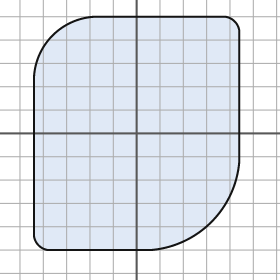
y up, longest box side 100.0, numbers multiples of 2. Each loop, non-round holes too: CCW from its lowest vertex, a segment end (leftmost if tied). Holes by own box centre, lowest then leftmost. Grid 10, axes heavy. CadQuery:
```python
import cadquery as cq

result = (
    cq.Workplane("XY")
    .moveTo(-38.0, -50.0)
    .lineTo(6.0, -50.0)
    .threePointArc((32.0, -38.0), (44.0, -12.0))
    .lineTo(44.0, 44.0)
    .threePointArc((42.0, 48.0), (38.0, 50.0))
    .lineTo(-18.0, 50.0)
    .threePointArc((-36.0, 42.0), (-44.0, 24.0))
    .lineTo(-44.0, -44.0)
    .threePointArc((-42.0, -48.0), (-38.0, -50.0))
    .close()
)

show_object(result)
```